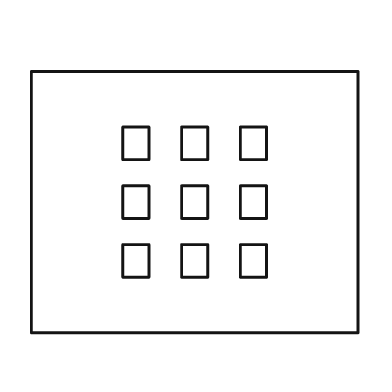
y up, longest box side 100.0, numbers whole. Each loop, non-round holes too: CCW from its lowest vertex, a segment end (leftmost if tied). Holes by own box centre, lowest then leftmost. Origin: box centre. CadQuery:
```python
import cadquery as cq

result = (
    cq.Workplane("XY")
    .moveTo(-50.0, -40.0)
    .lineTo(50.0, -40.0)
    .lineTo(50.0, 40.0)
    .lineTo(-50.0, 40.0)
    .close()
    .moveTo(-22.0, -23.0)
    .lineTo(-14.0, -23.0)
    .lineTo(-14.0, -13.0)
    .lineTo(-22.0, -13.0)
    .close()
    .moveTo(-4.0, -23.0)
    .lineTo(4.0, -23.0)
    .lineTo(4.0, -13.0)
    .lineTo(-4.0, -13.0)
    .close()
    .moveTo(14.0, -23.0)
    .lineTo(22.0, -23.0)
    .lineTo(22.0, -13.0)
    .lineTo(14.0, -13.0)
    .close()
    .moveTo(-22.0, -5.0)
    .lineTo(-14.0, -5.0)
    .lineTo(-14.0, 5.0)
    .lineTo(-22.0, 5.0)
    .close()
    .moveTo(-4.0, -5.0)
    .lineTo(4.0, -5.0)
    .lineTo(4.0, 5.0)
    .lineTo(-4.0, 5.0)
    .close()
    .moveTo(14.0, -5.0)
    .lineTo(22.0, -5.0)
    .lineTo(22.0, 5.0)
    .lineTo(14.0, 5.0)
    .close()
    .moveTo(-22.0, 13.0)
    .lineTo(-14.0, 13.0)
    .lineTo(-14.0, 23.0)
    .lineTo(-22.0, 23.0)
    .close()
    .moveTo(-4.0, 13.0)
    .lineTo(4.0, 13.0)
    .lineTo(4.0, 23.0)
    .lineTo(-4.0, 23.0)
    .close()
    .moveTo(14.0, 13.0)
    .lineTo(22.0, 13.0)
    .lineTo(22.0, 23.0)
    .lineTo(14.0, 23.0)
    .close()
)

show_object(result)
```